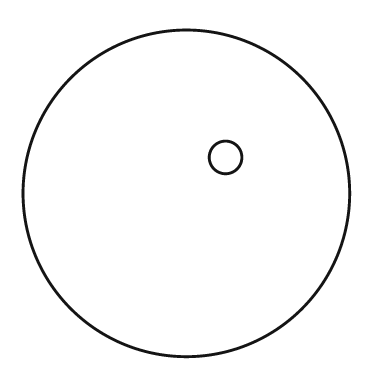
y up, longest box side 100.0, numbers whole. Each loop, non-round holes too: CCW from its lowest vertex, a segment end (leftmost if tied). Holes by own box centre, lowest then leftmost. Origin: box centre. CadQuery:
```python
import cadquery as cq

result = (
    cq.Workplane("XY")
    .moveTo(0.0, 0.0)
    .circle(50.0)
    .moveTo(12.0, 11.0)
    .circle(5.0)
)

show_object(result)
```